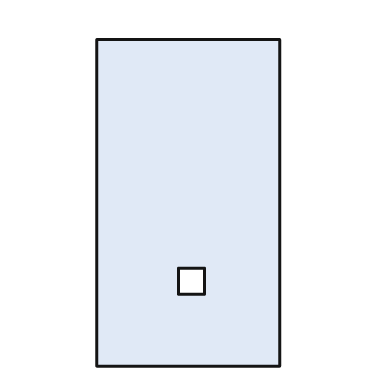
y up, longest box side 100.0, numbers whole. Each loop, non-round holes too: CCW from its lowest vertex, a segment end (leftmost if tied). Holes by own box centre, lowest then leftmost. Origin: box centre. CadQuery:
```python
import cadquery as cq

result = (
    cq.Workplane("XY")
    .moveTo(-28.0, -50.0)
    .lineTo(28.0, -50.0)
    .lineTo(28.0, 50.0)
    .lineTo(-28.0, 50.0)
    .close()
    .moveTo(-3.0, -28.0)
    .lineTo(5.0, -28.0)
    .lineTo(5.0, -20.0)
    .lineTo(-3.0, -20.0)
    .close()
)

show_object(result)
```